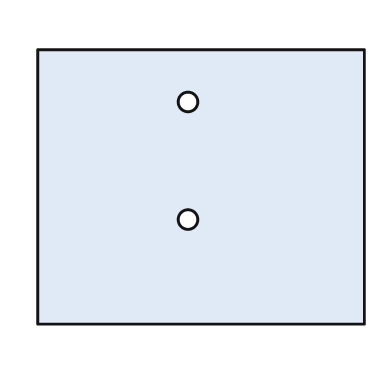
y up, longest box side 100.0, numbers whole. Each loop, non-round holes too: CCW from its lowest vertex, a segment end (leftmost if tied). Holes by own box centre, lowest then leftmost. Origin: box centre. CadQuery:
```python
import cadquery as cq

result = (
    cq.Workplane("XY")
    .moveTo(-50.0, -42.0)
    .lineTo(50.0, -42.0)
    .lineTo(50.0, 42.0)
    .lineTo(-50.0, 42.0)
    .close()
    .moveTo(-4.0, -10.0)
    .circle(3.0)
    .moveTo(-4.0, 26.0)
    .circle(3.0)
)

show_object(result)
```